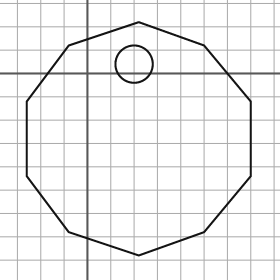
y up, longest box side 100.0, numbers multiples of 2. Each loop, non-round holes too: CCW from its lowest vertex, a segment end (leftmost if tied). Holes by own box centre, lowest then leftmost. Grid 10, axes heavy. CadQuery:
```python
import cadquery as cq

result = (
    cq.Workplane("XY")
    .moveTo(22.0, -78.0)
    .lineTo(50.0, -68.0)
    .lineTo(70.0, -44.0)
    .lineTo(70.0, -12.0)
    .lineTo(50.0, 12.0)
    .lineTo(22.0, 22.0)
    .lineTo(-8.0, 12.0)
    .lineTo(-26.0, -12.0)
    .lineTo(-26.0, -44.0)
    .lineTo(-8.0, -68.0)
    .close()
    .moveTo(20.0, 4.0)
    .circle(8.0)
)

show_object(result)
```